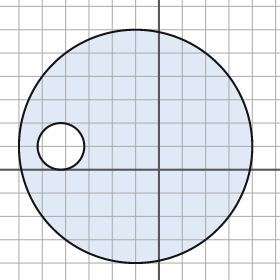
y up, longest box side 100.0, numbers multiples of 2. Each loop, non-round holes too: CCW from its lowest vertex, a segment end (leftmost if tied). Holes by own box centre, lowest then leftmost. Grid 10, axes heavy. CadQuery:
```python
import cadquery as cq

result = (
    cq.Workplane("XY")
    .moveTo(-10.0, 10.0)
    .circle(50.0)
    .moveTo(-42.0, 10.0)
    .circle(10.0)
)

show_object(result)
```